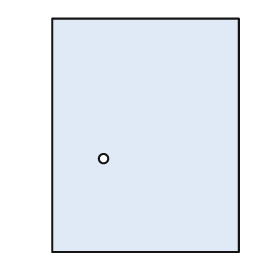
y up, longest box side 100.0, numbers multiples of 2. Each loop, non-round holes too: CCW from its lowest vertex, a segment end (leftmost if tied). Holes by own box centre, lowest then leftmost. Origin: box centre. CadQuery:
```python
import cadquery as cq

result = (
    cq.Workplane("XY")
    .moveTo(-40.0, -50.0)
    .lineTo(40.0, -50.0)
    .lineTo(40.0, 50.0)
    .lineTo(-40.0, 50.0)
    .close()
    .moveTo(-18.0, -10.0)
    .circle(2.0)
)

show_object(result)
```